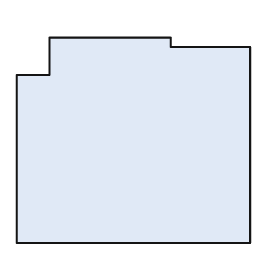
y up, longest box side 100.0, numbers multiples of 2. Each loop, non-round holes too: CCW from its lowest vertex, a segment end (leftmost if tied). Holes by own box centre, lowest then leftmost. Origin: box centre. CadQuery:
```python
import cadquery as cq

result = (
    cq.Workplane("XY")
    .moveTo(-50.0, -44.0)
    .lineTo(50.0, -44.0)
    .lineTo(50.0, 40.0)
    .lineTo(16.0, 40.0)
    .lineTo(16.0, 44.0)
    .lineTo(-36.0, 44.0)
    .lineTo(-36.0, 28.0)
    .lineTo(-50.0, 28.0)
    .close()
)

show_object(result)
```